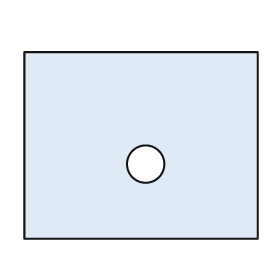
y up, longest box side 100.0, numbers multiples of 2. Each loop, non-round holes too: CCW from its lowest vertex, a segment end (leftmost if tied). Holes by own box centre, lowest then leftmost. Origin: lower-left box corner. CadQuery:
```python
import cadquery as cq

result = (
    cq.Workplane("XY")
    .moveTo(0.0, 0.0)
    .lineTo(100.0, 0.0)
    .lineTo(100.0, 80.0)
    .lineTo(0.0, 80.0)
    .close()
    .moveTo(52.0, 32.0)
    .circle(8.0)
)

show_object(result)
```